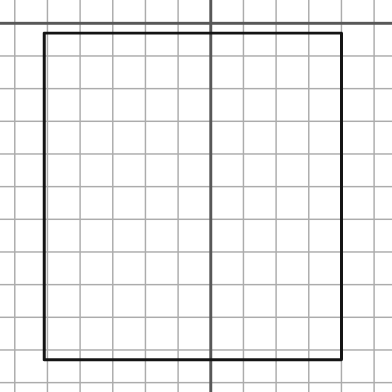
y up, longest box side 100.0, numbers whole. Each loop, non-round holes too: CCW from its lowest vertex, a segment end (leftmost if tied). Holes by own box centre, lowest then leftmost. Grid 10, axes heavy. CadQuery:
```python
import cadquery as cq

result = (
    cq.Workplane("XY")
    .moveTo(-51.0, -103.0)
    .lineTo(40.0, -103.0)
    .lineTo(40.0, -3.0)
    .lineTo(-51.0, -3.0)
    .close()
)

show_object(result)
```